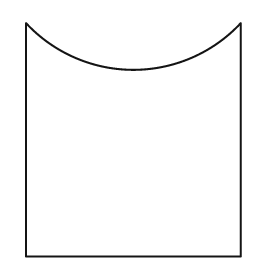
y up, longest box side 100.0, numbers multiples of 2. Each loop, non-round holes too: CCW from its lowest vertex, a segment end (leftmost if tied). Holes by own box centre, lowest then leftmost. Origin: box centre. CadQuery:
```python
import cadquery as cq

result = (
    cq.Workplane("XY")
    .moveTo(-46.0, -50.0)
    .lineTo(46.0, -50.0)
    .lineTo(46.0, 50.0)
    .threePointArc((0.0, 30.0), (-46.0, 50.0))
    .close()
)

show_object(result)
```